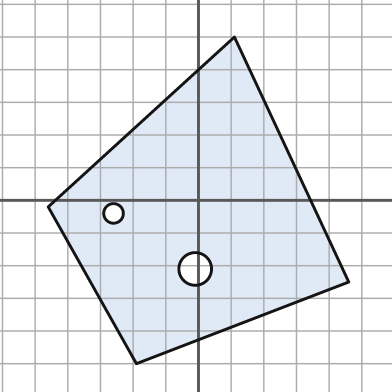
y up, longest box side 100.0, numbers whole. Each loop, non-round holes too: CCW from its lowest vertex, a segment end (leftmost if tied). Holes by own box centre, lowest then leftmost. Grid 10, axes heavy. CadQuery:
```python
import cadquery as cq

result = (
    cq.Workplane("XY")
    .moveTo(-19.0, -50.0)
    .lineTo(46.0, -25.0)
    .lineTo(11.0, 50.0)
    .lineTo(-46.0, -2.0)
    .close()
    .moveTo(-1.0, -21.0)
    .circle(5.0)
    .moveTo(-26.0, -4.0)
    .circle(3.0)
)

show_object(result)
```